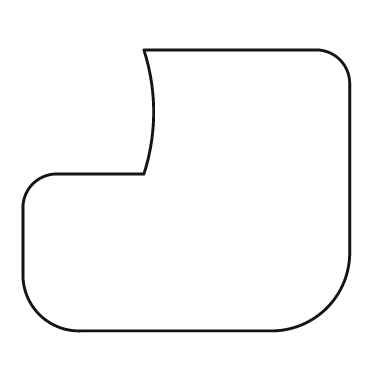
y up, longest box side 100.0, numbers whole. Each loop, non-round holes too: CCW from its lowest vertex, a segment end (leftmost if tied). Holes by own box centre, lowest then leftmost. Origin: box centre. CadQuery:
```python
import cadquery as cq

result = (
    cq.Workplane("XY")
    .moveTo(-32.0, -43.0)
    .lineTo(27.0, -43.0)
    .threePointArc((43.0, -36.0), (50.0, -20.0))
    .lineTo(50.0, 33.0)
    .threePointArc((47.0, 40.0), (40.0, 43.0))
    .lineTo(-13.0, 43.0)
    .threePointArc((-10.0, 24.0), (-13.0, 5.0))
    .lineTo(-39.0, 5.0)
    .threePointArc((-47.0, 2.0), (-50.0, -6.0))
    .lineTo(-50.0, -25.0)
    .threePointArc((-45.0, -38.0), (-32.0, -43.0))
    .close()
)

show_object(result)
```